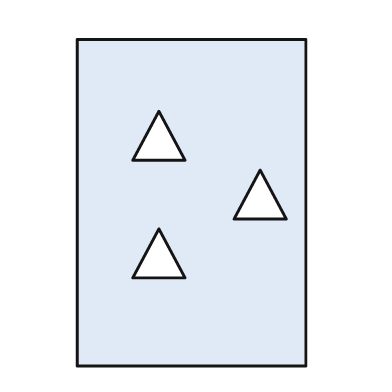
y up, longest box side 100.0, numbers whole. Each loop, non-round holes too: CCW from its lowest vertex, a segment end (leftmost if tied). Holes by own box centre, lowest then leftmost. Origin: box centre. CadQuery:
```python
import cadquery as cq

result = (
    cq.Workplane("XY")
    .moveTo(-35.0, -50.0)
    .lineTo(35.0, -50.0)
    .lineTo(35.0, 50.0)
    .lineTo(-35.0, 50.0)
    .close()
    .moveTo(-18.0, -23.0)
    .lineTo(-2.0, -23.0)
    .lineTo(-10.0, -8.0)
    .close()
    .moveTo(13.0, -5.0)
    .lineTo(29.0, -5.0)
    .lineTo(21.0, 10.0)
    .close()
    .moveTo(-18.0, 13.0)
    .lineTo(-2.0, 13.0)
    .lineTo(-10.0, 28.0)
    .close()
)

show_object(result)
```